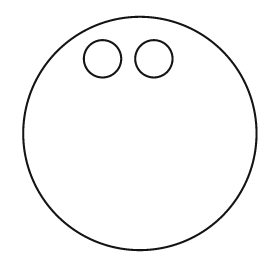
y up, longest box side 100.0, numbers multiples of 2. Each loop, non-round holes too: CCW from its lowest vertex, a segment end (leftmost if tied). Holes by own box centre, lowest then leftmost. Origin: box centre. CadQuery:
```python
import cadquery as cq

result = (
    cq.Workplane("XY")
    .moveTo(0.0, 0.0)
    .circle(50.0)
    .moveTo(-16.0, 32.0)
    .circle(8.0)
    .moveTo(6.0, 32.0)
    .circle(8.0)
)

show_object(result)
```